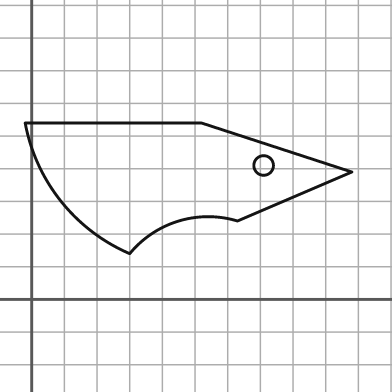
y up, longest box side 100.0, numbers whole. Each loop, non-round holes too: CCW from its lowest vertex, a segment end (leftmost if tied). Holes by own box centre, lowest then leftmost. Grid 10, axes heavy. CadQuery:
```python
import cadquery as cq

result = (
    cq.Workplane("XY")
    .moveTo(30.0, 14.0)
    .threePointArc((45.0, 24.0), (63.0, 24.0))
    .lineTo(98.0, 39.0)
    .lineTo(52.0, 54.0)
    .lineTo(-2.0, 54.0)
    .threePointArc((9.0, 30.0), (30.0, 14.0))
    .close()
    .moveTo(71.0, 41.0)
    .circle(3.0)
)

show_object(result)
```